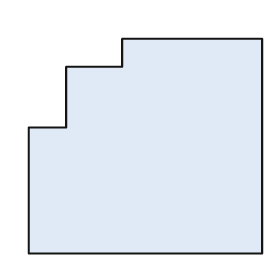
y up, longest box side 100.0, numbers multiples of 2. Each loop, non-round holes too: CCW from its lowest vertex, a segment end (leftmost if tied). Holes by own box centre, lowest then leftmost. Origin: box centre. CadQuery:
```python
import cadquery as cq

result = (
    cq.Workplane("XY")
    .moveTo(-50.0, -46.0)
    .lineTo(50.0, -46.0)
    .lineTo(50.0, 46.0)
    .lineTo(-10.0, 46.0)
    .lineTo(-10.0, 34.0)
    .lineTo(-34.0, 34.0)
    .lineTo(-34.0, 8.0)
    .lineTo(-50.0, 8.0)
    .close()
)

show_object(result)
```